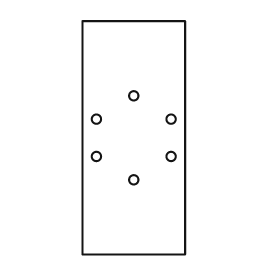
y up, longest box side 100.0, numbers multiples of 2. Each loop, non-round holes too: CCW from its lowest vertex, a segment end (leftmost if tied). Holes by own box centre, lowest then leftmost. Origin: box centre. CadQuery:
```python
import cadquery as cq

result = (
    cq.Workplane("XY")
    .moveTo(-22.0, -50.0)
    .lineTo(22.0, -50.0)
    .lineTo(22.0, 50.0)
    .lineTo(-22.0, 50.0)
    .close()
    .moveTo(0.0, -18.0)
    .circle(2.0)
    .moveTo(-16.0, -8.0)
    .circle(2.0)
    .moveTo(16.0, -8.0)
    .circle(2.0)
    .moveTo(-16.0, 8.0)
    .circle(2.0)
    .moveTo(16.0, 8.0)
    .circle(2.0)
    .moveTo(0.0, 18.0)
    .circle(2.0)
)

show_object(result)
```